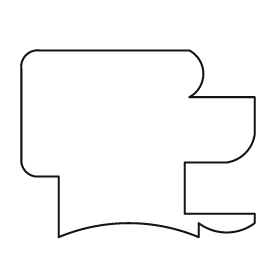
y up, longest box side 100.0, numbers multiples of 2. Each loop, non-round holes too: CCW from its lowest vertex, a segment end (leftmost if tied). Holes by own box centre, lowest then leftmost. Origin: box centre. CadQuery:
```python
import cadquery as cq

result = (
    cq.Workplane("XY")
    .moveTo(-34.0, -40.0)
    .threePointArc((-4.0, -34.0), (26.0, -40.0))
    .lineTo(26.0, -34.0)
    .threePointArc((38.0, -38.0), (50.0, -34.0))
    .lineTo(50.0, -30.0)
    .lineTo(20.0, -30.0)
    .lineTo(20.0, -8.0)
    .lineTo(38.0, -8.0)
    .threePointArc((46.0, -4.0), (50.0, 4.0))
    .lineTo(50.0, 20.0)
    .lineTo(22.0, 20.0)
    .threePointArc((28.0, 30.0), (22.0, 40.0))
    .lineTo(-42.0, 40.0)
    .threePointArc((-48.0, 38.0), (-50.0, 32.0))
    .lineTo(-50.0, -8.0)
    .threePointArc((-48.0, -12.0), (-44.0, -14.0))
    .lineTo(-34.0, -14.0)
    .close()
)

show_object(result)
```